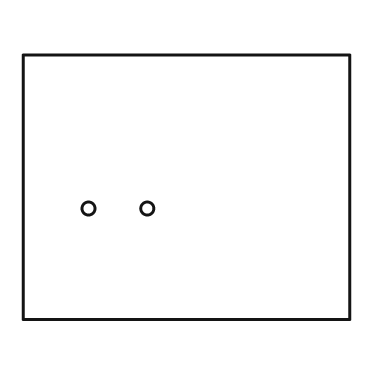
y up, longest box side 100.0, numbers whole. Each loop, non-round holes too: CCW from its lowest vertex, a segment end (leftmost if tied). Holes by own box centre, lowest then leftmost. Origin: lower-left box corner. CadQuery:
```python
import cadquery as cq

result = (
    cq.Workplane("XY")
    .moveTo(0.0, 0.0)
    .lineTo(100.0, 0.0)
    .lineTo(100.0, 81.0)
    .lineTo(0.0, 81.0)
    .close()
    .moveTo(20.0, 34.0)
    .circle(2.0)
    .moveTo(38.0, 34.0)
    .circle(2.0)
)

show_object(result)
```